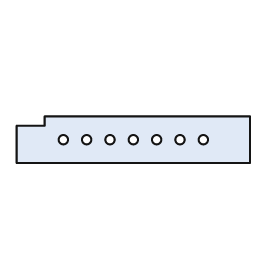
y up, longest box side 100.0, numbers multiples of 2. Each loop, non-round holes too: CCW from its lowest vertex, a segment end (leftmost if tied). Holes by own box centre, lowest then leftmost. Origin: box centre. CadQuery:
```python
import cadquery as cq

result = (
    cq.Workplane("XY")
    .moveTo(-50.0, -10.0)
    .lineTo(50.0, -10.0)
    .lineTo(50.0, 10.0)
    .lineTo(-38.0, 10.0)
    .lineTo(-38.0, 6.0)
    .lineTo(-50.0, 6.0)
    .close()
    .moveTo(-30.0, 0.0)
    .circle(2.0)
    .moveTo(-20.0, 0.0)
    .circle(2.0)
    .moveTo(-10.0, 0.0)
    .circle(2.0)
    .moveTo(0.0, 0.0)
    .circle(2.0)
    .moveTo(10.0, 0.0)
    .circle(2.0)
    .moveTo(20.0, 0.0)
    .circle(2.0)
    .moveTo(30.0, 0.0)
    .circle(2.0)
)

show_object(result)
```